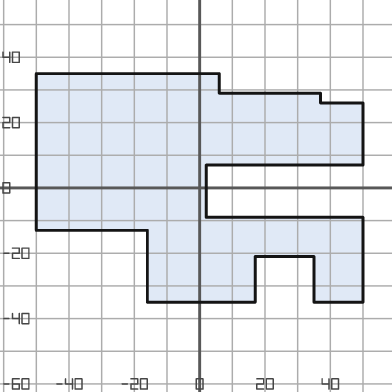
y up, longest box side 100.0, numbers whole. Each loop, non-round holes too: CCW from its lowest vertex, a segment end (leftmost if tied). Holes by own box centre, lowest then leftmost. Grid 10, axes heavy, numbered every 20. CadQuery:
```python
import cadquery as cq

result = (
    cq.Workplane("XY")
    .moveTo(-16.0, -35.0)
    .lineTo(17.0, -35.0)
    .lineTo(17.0, -21.0)
    .lineTo(35.0, -21.0)
    .lineTo(35.0, -35.0)
    .lineTo(50.0, -35.0)
    .lineTo(50.0, -9.0)
    .lineTo(2.0, -9.0)
    .lineTo(2.0, 7.0)
    .lineTo(50.0, 7.0)
    .lineTo(50.0, 26.0)
    .lineTo(37.0, 26.0)
    .lineTo(37.0, 29.0)
    .lineTo(6.0, 29.0)
    .lineTo(6.0, 35.0)
    .lineTo(-50.0, 35.0)
    .lineTo(-50.0, -13.0)
    .lineTo(-16.0, -13.0)
    .close()
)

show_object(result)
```